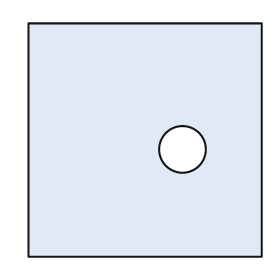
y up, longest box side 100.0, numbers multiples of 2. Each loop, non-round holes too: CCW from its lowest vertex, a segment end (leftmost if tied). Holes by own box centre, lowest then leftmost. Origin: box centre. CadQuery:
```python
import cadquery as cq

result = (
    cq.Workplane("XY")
    .moveTo(-50.0, -50.0)
    .lineTo(50.0, -50.0)
    .lineTo(50.0, 50.0)
    .lineTo(-50.0, 50.0)
    .close()
    .moveTo(16.0, -4.0)
    .circle(10.0)
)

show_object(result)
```